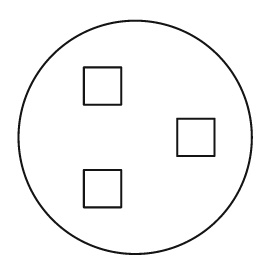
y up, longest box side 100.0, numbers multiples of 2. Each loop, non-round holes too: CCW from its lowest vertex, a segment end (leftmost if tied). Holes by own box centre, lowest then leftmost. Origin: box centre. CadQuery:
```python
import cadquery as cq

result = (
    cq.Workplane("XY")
    .moveTo(0.0, 0.0)
    .circle(50.0)
    .moveTo(-22.0, -30.0)
    .lineTo(-6.0, -30.0)
    .lineTo(-6.0, -14.0)
    .lineTo(-22.0, -14.0)
    .close()
    .moveTo(18.0, -8.0)
    .lineTo(34.0, -8.0)
    .lineTo(34.0, 8.0)
    .lineTo(18.0, 8.0)
    .close()
    .moveTo(-22.0, 14.0)
    .lineTo(-6.0, 14.0)
    .lineTo(-6.0, 30.0)
    .lineTo(-22.0, 30.0)
    .close()
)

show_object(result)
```